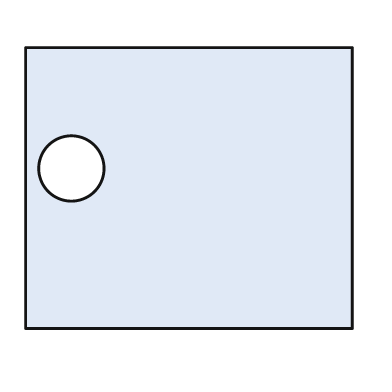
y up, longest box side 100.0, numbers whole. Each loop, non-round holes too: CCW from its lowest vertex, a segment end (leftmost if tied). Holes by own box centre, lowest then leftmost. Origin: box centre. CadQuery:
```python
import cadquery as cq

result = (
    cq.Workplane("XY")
    .moveTo(-50.0, -43.0)
    .lineTo(50.0, -43.0)
    .lineTo(50.0, 43.0)
    .lineTo(-50.0, 43.0)
    .close()
    .moveTo(-36.0, 6.0)
    .circle(10.0)
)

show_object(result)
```